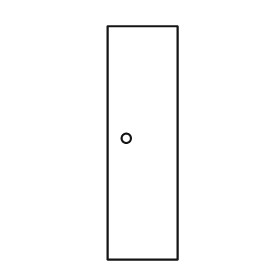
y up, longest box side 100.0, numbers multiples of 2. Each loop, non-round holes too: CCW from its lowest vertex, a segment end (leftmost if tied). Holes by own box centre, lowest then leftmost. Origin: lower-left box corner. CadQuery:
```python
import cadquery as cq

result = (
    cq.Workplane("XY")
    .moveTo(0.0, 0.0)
    .lineTo(30.0, 0.0)
    .lineTo(30.0, 100.0)
    .lineTo(0.0, 100.0)
    .close()
    .moveTo(8.0, 52.0)
    .circle(2.0)
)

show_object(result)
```